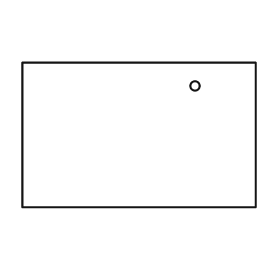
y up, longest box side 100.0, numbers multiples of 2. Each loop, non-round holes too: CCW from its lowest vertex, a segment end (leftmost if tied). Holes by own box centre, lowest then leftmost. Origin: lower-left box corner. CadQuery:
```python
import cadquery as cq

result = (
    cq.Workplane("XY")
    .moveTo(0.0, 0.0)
    .lineTo(100.0, 0.0)
    .lineTo(100.0, 62.0)
    .lineTo(0.0, 62.0)
    .close()
    .moveTo(74.0, 52.0)
    .circle(2.0)
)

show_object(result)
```